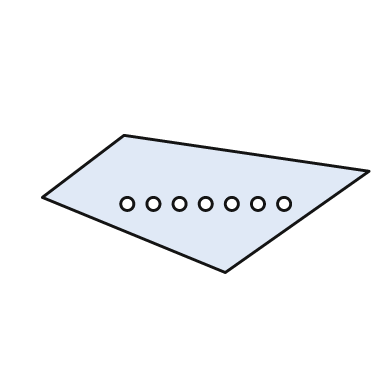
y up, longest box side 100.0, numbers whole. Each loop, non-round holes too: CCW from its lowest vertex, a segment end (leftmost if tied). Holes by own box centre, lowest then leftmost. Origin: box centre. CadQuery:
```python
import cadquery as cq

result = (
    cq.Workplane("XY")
    .moveTo(6.0, -21.0)
    .lineTo(50.0, 10.0)
    .lineTo(-25.0, 21.0)
    .lineTo(-50.0, 2.0)
    .close()
    .moveTo(-24.0, 0.0)
    .circle(2.0)
    .moveTo(-16.0, 0.0)
    .circle(2.0)
    .moveTo(-8.0, 0.0)
    .circle(2.0)
    .moveTo(0.0, 0.0)
    .circle(2.0)
    .moveTo(8.0, 0.0)
    .circle(2.0)
    .moveTo(16.0, 0.0)
    .circle(2.0)
    .moveTo(24.0, 0.0)
    .circle(2.0)
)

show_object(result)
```